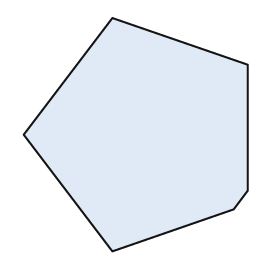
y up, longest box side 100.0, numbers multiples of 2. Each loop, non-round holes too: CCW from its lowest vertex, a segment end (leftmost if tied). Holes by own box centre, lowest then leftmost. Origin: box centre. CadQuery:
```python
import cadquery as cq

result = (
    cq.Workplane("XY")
    .moveTo(-10.0, -50.0)
    .lineTo(42.0, -32.0)
    .lineTo(48.0, -24.0)
    .lineTo(48.0, 30.0)
    .lineTo(-10.0, 50.0)
    .lineTo(-48.0, 0.0)
    .close()
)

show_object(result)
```